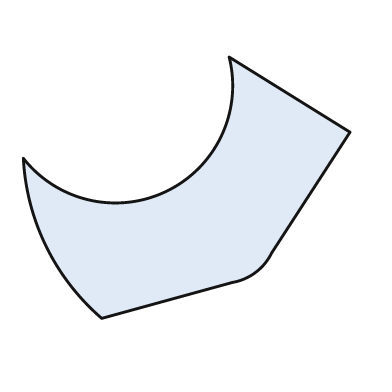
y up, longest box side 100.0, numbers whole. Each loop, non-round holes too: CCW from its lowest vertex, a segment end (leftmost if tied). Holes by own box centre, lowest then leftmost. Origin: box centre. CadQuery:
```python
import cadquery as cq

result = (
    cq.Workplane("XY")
    .moveTo(-26.0, -40.0)
    .lineTo(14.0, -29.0)
    .threePointArc((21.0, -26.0), (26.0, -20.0))
    .lineTo(50.0, 17.0)
    .lineTo(13.0, 40.0)
    .threePointArc((-6.0, -1.0), (-50.0, 9.0))
    .threePointArc((-43.0, -18.0), (-26.0, -40.0))
    .close()
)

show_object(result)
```